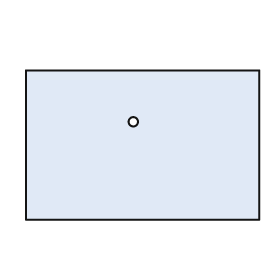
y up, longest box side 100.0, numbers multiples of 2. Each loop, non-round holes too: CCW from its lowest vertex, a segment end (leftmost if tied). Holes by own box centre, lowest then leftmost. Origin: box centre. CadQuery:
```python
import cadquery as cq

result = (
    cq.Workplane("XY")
    .moveTo(-50.0, -32.0)
    .lineTo(50.0, -32.0)
    .lineTo(50.0, 32.0)
    .lineTo(-50.0, 32.0)
    .close()
    .moveTo(-4.0, 10.0)
    .circle(2.0)
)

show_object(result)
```